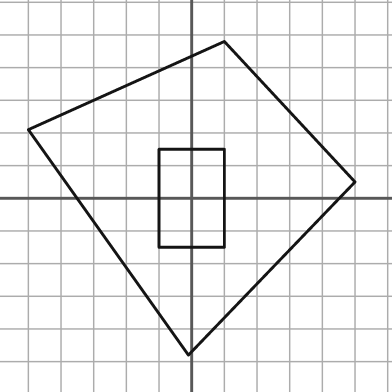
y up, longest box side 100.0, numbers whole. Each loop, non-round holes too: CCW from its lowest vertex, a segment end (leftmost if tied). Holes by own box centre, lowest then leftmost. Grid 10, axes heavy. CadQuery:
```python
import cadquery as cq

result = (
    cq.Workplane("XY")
    .moveTo(-1.0, -48.0)
    .lineTo(50.0, 5.0)
    .lineTo(10.0, 48.0)
    .lineTo(-50.0, 21.0)
    .close()
    .moveTo(-10.0, -15.0)
    .lineTo(10.0, -15.0)
    .lineTo(10.0, 15.0)
    .lineTo(-10.0, 15.0)
    .close()
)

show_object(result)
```